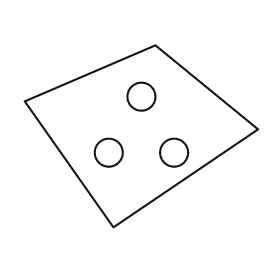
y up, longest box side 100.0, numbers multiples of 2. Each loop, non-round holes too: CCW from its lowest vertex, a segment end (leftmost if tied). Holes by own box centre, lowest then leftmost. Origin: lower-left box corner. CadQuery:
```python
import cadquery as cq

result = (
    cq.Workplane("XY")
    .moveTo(38.0, 0.0)
    .lineTo(100.0, 42.0)
    .lineTo(56.0, 78.0)
    .lineTo(0.0, 54.0)
    .close()
    .moveTo(36.0, 32.0)
    .circle(6.0)
    .moveTo(64.0, 32.0)
    .circle(6.0)
    .moveTo(50.0, 56.0)
    .circle(6.0)
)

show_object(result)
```